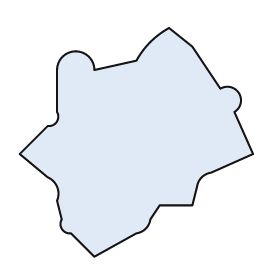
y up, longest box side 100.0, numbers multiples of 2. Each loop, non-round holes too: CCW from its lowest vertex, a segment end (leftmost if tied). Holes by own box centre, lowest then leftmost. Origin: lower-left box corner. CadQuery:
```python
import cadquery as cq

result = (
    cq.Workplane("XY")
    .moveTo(32.0, 0.0)
    .lineTo(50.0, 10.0)
    .threePointArc((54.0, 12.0), (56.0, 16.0))
    .lineTo(60.0, 22.0)
    .lineTo(74.0, 22.0)
    .lineTo(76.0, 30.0)
    .threePointArc((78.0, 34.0), (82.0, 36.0))
    .lineTo(100.0, 44.0)
    .lineTo(92.0, 62.0)
    .threePointArc((94.0, 70.0), (86.0, 72.0))
    .lineTo(74.0, 90.0)
    .lineTo(64.0, 98.0)
    .threePointArc((56.0, 92.0), (50.0, 84.0))
    .lineTo(32.0, 80.0)
    .threePointArc((24.0, 88.0), (16.0, 80.0))
    .lineTo(16.0, 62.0)
    .threePointArc((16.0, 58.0), (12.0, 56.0))
    .lineTo(0.0, 44.0)
    .lineTo(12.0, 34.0)
    .threePointArc((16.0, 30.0), (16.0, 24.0))
    .lineTo(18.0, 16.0)
    .threePointArc((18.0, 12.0), (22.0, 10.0))
    .close()
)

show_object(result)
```